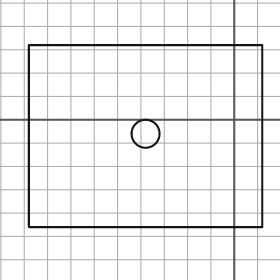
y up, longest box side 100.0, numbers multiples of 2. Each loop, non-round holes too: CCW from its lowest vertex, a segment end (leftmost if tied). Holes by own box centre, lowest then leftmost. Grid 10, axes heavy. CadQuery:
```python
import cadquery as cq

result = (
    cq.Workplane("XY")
    .moveTo(-88.0, -46.0)
    .lineTo(12.0, -46.0)
    .lineTo(12.0, 32.0)
    .lineTo(-88.0, 32.0)
    .close()
    .moveTo(-38.0, -6.0)
    .circle(6.0)
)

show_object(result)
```